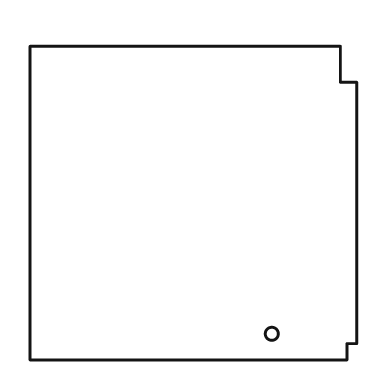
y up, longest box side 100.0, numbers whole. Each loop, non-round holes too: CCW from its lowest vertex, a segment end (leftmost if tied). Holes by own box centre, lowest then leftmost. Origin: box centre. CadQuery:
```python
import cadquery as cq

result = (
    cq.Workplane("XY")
    .moveTo(-50.0, -48.0)
    .lineTo(47.0, -48.0)
    .lineTo(47.0, -43.0)
    .lineTo(50.0, -43.0)
    .lineTo(50.0, 37.0)
    .lineTo(45.0, 37.0)
    .lineTo(45.0, 48.0)
    .lineTo(-50.0, 48.0)
    .close()
    .moveTo(24.0, -40.0)
    .circle(2.0)
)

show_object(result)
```